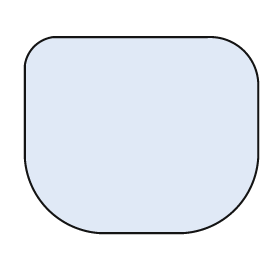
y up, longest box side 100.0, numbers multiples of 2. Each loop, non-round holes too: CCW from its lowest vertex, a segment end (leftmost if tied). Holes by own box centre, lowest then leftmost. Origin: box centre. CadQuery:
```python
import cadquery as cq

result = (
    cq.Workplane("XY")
    .moveTo(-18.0, -42.0)
    .lineTo(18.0, -42.0)
    .threePointArc((40.0, -32.0), (50.0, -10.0))
    .lineTo(50.0, 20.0)
    .threePointArc((44.0, 36.0), (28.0, 42.0))
    .lineTo(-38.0, 42.0)
    .threePointArc((-46.0, 38.0), (-50.0, 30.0))
    .lineTo(-50.0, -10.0)
    .threePointArc((-40.0, -32.0), (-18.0, -42.0))
    .close()
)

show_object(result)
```